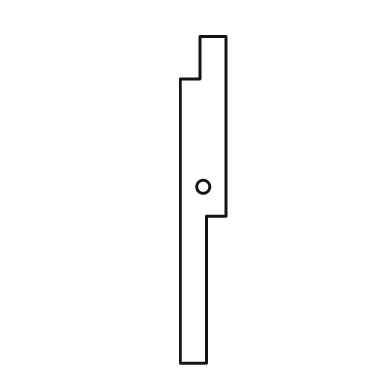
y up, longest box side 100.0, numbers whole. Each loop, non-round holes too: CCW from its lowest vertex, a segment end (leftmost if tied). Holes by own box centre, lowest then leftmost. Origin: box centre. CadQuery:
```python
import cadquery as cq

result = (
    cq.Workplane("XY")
    .moveTo(-7.0, -50.0)
    .lineTo(1.0, -50.0)
    .lineTo(1.0, -5.0)
    .lineTo(7.0, -5.0)
    .lineTo(7.0, 50.0)
    .lineTo(-1.0, 50.0)
    .lineTo(-1.0, 37.0)
    .lineTo(-7.0, 37.0)
    .close()
    .moveTo(0.0, 4.0)
    .circle(2.0)
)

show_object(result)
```